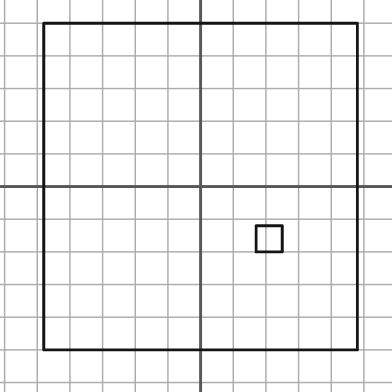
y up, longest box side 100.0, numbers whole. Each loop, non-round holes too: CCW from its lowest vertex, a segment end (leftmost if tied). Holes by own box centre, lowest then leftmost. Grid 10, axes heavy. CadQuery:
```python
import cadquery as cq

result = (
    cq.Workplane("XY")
    .moveTo(-48.0, -50.0)
    .lineTo(48.0, -50.0)
    .lineTo(48.0, 50.0)
    .lineTo(-48.0, 50.0)
    .close()
    .moveTo(17.0, -20.0)
    .lineTo(25.0, -20.0)
    .lineTo(25.0, -12.0)
    .lineTo(17.0, -12.0)
    .close()
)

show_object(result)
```